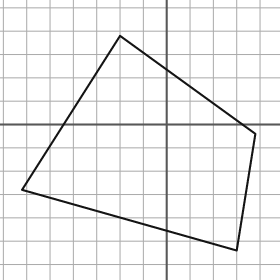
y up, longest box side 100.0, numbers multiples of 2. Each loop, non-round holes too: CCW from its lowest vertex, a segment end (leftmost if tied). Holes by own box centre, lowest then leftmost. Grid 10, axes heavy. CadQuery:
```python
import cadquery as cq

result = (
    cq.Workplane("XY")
    .moveTo(30.0, -54.0)
    .lineTo(38.0, -4.0)
    .lineTo(-20.0, 38.0)
    .lineTo(-62.0, -28.0)
    .close()
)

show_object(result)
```